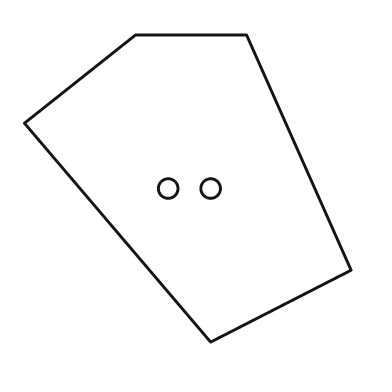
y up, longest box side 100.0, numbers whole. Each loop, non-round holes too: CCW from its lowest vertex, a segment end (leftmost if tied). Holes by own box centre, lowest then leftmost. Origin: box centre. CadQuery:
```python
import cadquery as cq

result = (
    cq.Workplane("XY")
    .moveTo(7.0, -47.0)
    .lineTo(50.0, -25.0)
    .lineTo(18.0, 47.0)
    .lineTo(-16.0, 47.0)
    .lineTo(-50.0, 20.0)
    .close()
    .moveTo(-6.0, 0.0)
    .circle(3.0)
    .moveTo(7.0, 0.0)
    .circle(3.0)
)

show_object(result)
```